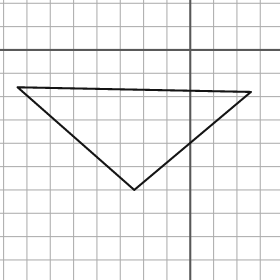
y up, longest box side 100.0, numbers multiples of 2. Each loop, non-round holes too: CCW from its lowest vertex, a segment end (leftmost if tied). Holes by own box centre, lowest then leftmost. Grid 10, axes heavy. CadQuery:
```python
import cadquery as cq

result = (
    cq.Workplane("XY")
    .moveTo(-24.0, -60.0)
    .lineTo(26.0, -18.0)
    .lineTo(-74.0, -16.0)
    .close()
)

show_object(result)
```